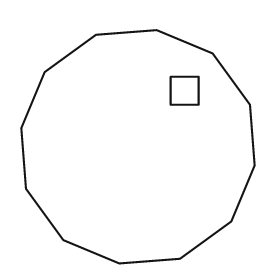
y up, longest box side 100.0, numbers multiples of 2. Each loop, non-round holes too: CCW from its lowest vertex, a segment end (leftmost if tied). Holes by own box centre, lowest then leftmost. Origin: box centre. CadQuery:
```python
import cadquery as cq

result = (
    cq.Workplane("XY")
    .moveTo(-8.0, -50.0)
    .lineTo(18.0, -48.0)
    .lineTo(40.0, -32.0)
    .lineTo(50.0, -8.0)
    .lineTo(48.0, 18.0)
    .lineTo(32.0, 40.0)
    .lineTo(8.0, 50.0)
    .lineTo(-18.0, 48.0)
    .lineTo(-40.0, 32.0)
    .lineTo(-50.0, 8.0)
    .lineTo(-48.0, -18.0)
    .lineTo(-32.0, -40.0)
    .close()
    .moveTo(14.0, 18.0)
    .lineTo(26.0, 18.0)
    .lineTo(26.0, 30.0)
    .lineTo(14.0, 30.0)
    .close()
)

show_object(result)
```